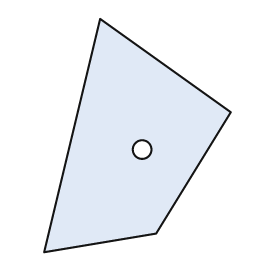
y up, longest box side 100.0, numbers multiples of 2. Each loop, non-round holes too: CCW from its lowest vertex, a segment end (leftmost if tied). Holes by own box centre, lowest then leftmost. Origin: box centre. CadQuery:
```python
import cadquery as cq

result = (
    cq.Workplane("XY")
    .moveTo(-40.0, -50.0)
    .lineTo(8.0, -42.0)
    .lineTo(40.0, 10.0)
    .lineTo(-16.0, 50.0)
    .close()
    .moveTo(2.0, -6.0)
    .circle(4.0)
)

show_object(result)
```